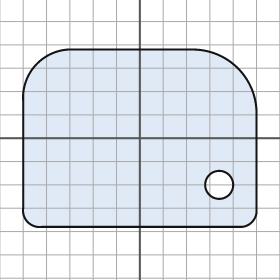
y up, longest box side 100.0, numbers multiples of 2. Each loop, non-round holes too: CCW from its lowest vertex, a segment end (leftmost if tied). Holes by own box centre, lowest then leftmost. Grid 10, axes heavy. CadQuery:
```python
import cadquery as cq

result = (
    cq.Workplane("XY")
    .moveTo(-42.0, -38.0)
    .lineTo(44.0, -38.0)
    .threePointArc((48.0, -36.0), (50.0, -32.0))
    .lineTo(50.0, 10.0)
    .threePointArc((42.0, 30.0), (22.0, 38.0))
    .lineTo(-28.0, 38.0)
    .threePointArc((-44.0, 32.0), (-50.0, 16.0))
    .lineTo(-50.0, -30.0)
    .threePointArc((-48.0, -36.0), (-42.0, -38.0))
    .close()
    .moveTo(34.0, -20.0)
    .circle(6.0)
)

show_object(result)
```